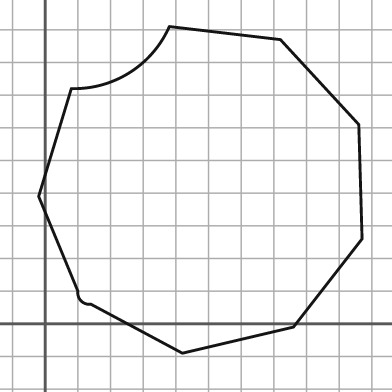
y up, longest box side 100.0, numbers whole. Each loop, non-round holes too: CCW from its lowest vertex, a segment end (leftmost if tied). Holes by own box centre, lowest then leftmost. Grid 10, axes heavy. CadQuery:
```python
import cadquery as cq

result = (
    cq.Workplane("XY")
    .moveTo(42.0, -9.0)
    .lineTo(76.0, -1.0)
    .lineTo(97.0, 26.0)
    .lineTo(96.0, 61.0)
    .lineTo(72.0, 87.0)
    .lineTo(38.0, 91.0)
    .threePointArc((26.0, 77.0), (8.0, 72.0))
    .lineTo(-2.0, 39.0)
    .lineTo(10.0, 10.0)
    .threePointArc((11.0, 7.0), (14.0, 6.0))
    .close()
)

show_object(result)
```